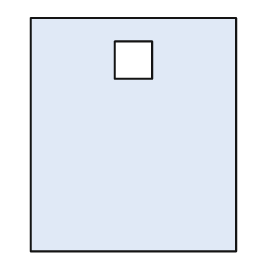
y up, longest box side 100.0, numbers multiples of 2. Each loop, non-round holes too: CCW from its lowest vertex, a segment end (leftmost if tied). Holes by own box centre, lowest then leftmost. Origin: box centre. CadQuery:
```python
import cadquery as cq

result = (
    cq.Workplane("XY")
    .moveTo(-44.0, -50.0)
    .lineTo(44.0, -50.0)
    .lineTo(44.0, 50.0)
    .lineTo(-44.0, 50.0)
    .close()
    .moveTo(-8.0, 24.0)
    .lineTo(8.0, 24.0)
    .lineTo(8.0, 40.0)
    .lineTo(-8.0, 40.0)
    .close()
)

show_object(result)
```